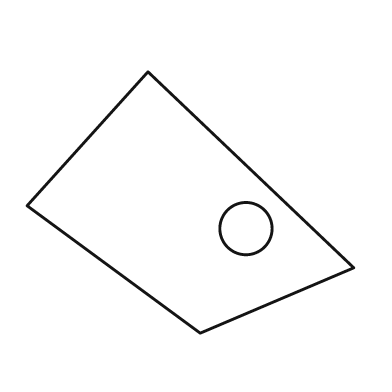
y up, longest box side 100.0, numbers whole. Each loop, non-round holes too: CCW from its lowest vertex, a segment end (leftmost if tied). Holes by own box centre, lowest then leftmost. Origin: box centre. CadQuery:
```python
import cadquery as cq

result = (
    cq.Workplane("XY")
    .moveTo(3.0, -40.0)
    .lineTo(50.0, -20.0)
    .lineTo(-13.0, 40.0)
    .lineTo(-50.0, -1.0)
    .close()
    .moveTo(17.0, -8.0)
    .circle(8.0)
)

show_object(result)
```